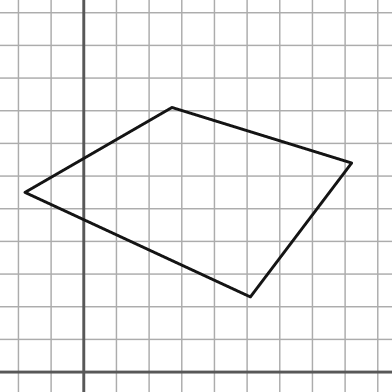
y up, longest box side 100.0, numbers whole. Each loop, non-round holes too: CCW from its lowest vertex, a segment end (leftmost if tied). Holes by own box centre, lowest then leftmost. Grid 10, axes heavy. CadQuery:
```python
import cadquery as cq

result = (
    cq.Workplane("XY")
    .moveTo(51.0, 23.0)
    .lineTo(82.0, 64.0)
    .lineTo(27.0, 81.0)
    .lineTo(-18.0, 55.0)
    .close()
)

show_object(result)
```